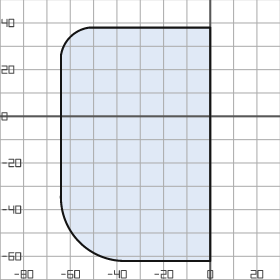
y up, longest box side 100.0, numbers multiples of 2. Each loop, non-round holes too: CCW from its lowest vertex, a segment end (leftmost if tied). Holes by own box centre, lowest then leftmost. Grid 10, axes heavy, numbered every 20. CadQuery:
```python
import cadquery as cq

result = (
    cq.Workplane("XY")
    .moveTo(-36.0, -62.0)
    .lineTo(0.0, -62.0)
    .lineTo(0.0, 38.0)
    .lineTo(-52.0, 38.0)
    .threePointArc((-60.0, 34.0), (-64.0, 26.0))
    .lineTo(-64.0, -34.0)
    .threePointArc((-56.0, -54.0), (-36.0, -62.0))
    .close()
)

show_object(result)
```